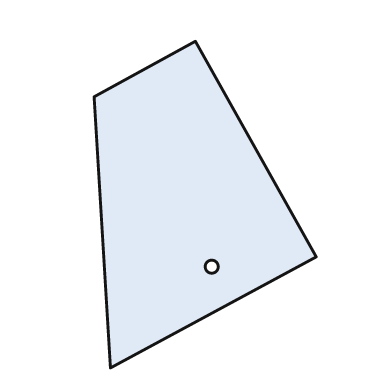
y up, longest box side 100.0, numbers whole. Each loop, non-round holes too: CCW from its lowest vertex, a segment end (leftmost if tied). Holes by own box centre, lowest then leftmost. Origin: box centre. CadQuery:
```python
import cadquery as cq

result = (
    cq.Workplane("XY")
    .moveTo(-29.0, -50.0)
    .lineTo(34.0, -16.0)
    .lineTo(-3.0, 50.0)
    .lineTo(-34.0, 33.0)
    .close()
    .moveTo(2.0, -19.0)
    .circle(2.0)
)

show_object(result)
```